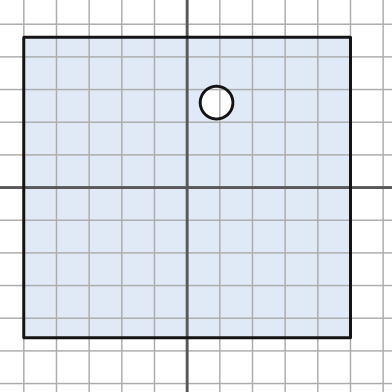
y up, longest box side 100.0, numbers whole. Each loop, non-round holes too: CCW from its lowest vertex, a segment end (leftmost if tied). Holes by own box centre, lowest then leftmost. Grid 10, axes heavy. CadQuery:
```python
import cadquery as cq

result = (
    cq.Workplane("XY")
    .moveTo(-50.0, -46.0)
    .lineTo(50.0, -46.0)
    .lineTo(50.0, 46.0)
    .lineTo(-50.0, 46.0)
    .close()
    .moveTo(9.0, 26.0)
    .circle(5.0)
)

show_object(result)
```